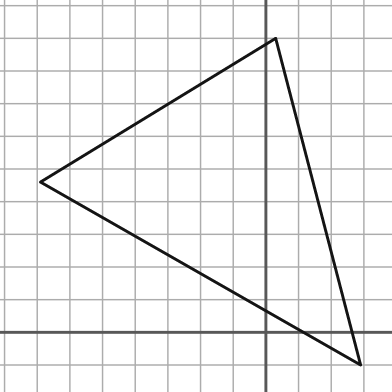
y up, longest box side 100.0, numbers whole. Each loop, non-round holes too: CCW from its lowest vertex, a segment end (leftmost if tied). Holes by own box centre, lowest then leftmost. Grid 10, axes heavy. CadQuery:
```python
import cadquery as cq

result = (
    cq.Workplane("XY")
    .moveTo(29.0, -10.0)
    .lineTo(3.0, 90.0)
    .lineTo(-69.0, 46.0)
    .close()
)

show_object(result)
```